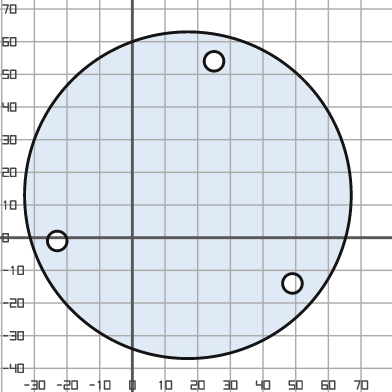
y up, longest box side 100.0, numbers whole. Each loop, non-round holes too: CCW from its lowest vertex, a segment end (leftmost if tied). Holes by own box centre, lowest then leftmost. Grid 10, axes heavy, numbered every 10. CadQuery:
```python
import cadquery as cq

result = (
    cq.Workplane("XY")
    .moveTo(17.0, 13.0)
    .circle(50.0)
    .moveTo(49.0, -14.0)
    .circle(3.0)
    .moveTo(-23.0, -1.0)
    .circle(3.0)
    .moveTo(25.0, 54.0)
    .circle(3.0)
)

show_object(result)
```